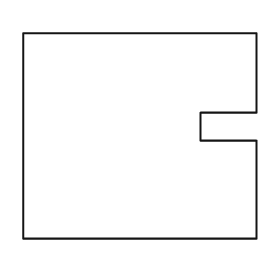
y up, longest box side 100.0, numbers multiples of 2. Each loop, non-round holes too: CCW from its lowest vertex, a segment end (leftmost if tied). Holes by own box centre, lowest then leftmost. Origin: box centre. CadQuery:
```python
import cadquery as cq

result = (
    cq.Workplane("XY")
    .moveTo(-50.0, -44.0)
    .lineTo(50.0, -44.0)
    .lineTo(50.0, -2.0)
    .lineTo(26.0, -2.0)
    .lineTo(26.0, 10.0)
    .lineTo(50.0, 10.0)
    .lineTo(50.0, 44.0)
    .lineTo(-50.0, 44.0)
    .close()
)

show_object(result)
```